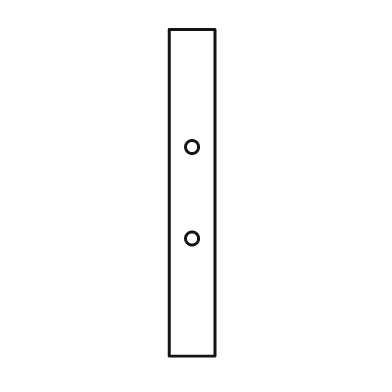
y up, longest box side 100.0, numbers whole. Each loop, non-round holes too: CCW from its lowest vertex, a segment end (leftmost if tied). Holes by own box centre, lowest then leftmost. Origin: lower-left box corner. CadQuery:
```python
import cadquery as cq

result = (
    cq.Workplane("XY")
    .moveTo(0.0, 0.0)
    .lineTo(14.0, 0.0)
    .lineTo(14.0, 100.0)
    .lineTo(0.0, 100.0)
    .close()
    .moveTo(7.0, 36.0)
    .circle(2.0)
    .moveTo(7.0, 64.0)
    .circle(2.0)
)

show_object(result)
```